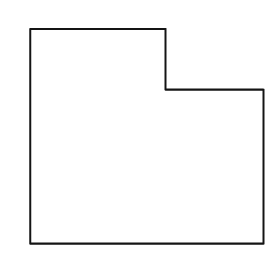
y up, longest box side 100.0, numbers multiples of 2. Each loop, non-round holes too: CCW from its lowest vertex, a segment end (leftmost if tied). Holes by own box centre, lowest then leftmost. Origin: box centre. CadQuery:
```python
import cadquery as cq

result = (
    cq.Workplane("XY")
    .moveTo(-50.0, -46.0)
    .lineTo(50.0, -46.0)
    .lineTo(50.0, 20.0)
    .lineTo(8.0, 20.0)
    .lineTo(8.0, 46.0)
    .lineTo(-50.0, 46.0)
    .close()
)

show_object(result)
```